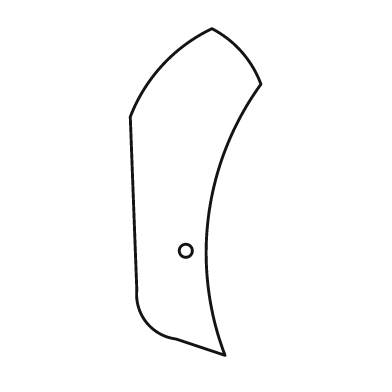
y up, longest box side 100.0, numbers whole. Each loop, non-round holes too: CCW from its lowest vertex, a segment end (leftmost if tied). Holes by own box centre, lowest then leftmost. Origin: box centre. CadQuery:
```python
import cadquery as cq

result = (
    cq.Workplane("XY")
    .moveTo(9.0, -50.0)
    .threePointArc((4.0, -7.0), (20.0, 33.0))
    .threePointArc((14.0, 43.0), (5.0, 50.0))
    .threePointArc((-10.0, 39.0), (-20.0, 23.0))
    .lineTo(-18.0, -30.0)
    .threePointArc((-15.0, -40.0), (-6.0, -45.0))
    .close()
    .moveTo(-3.0, -18.0)
    .circle(2.0)
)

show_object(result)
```